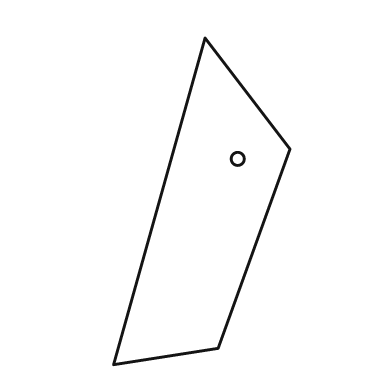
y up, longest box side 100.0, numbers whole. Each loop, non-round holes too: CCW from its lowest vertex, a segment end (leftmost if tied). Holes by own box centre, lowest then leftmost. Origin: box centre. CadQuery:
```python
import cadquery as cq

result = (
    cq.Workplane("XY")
    .moveTo(-27.0, -50.0)
    .lineTo(5.0, -45.0)
    .lineTo(27.0, 16.0)
    .lineTo(1.0, 50.0)
    .close()
    .moveTo(11.0, 13.0)
    .circle(2.0)
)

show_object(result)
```